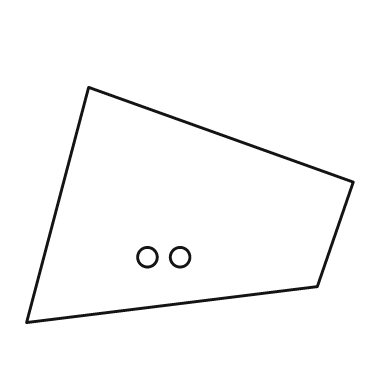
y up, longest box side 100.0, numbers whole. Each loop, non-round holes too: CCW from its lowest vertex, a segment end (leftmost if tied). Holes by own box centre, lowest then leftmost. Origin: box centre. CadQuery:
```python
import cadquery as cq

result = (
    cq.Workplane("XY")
    .moveTo(-50.0, -36.0)
    .lineTo(39.0, -25.0)
    .lineTo(50.0, 7.0)
    .lineTo(-31.0, 36.0)
    .close()
    .moveTo(-13.0, -16.0)
    .circle(3.0)
    .moveTo(-3.0, -16.0)
    .circle(3.0)
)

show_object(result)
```